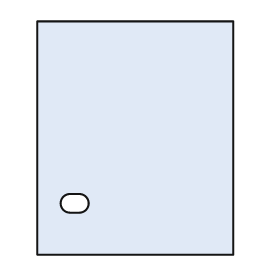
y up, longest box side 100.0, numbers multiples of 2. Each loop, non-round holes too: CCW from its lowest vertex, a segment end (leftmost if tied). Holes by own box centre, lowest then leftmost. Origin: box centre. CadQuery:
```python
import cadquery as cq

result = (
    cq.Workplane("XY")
    .moveTo(-42.0, -50.0)
    .lineTo(42.0, -50.0)
    .lineTo(42.0, 50.0)
    .lineTo(-42.0, 50.0)
    .close()
    .moveTo(-28.0, -32.0)
    .lineTo(-24.0, -32.0)
    .threePointArc((-20.0, -28.0), (-24.0, -24.0))
    .lineTo(-28.0, -24.0)
    .threePointArc((-32.0, -28.0), (-28.0, -32.0))
    .close()
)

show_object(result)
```